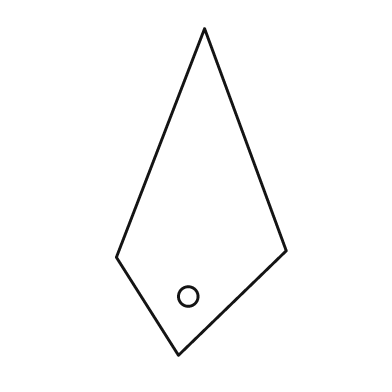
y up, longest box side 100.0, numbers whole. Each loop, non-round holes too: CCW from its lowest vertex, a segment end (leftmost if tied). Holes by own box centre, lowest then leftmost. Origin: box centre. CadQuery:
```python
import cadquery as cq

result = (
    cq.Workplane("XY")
    .moveTo(-7.0, -50.0)
    .lineTo(26.0, -18.0)
    .lineTo(1.0, 50.0)
    .lineTo(-26.0, -20.0)
    .close()
    .moveTo(-4.0, -32.0)
    .circle(3.0)
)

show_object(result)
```